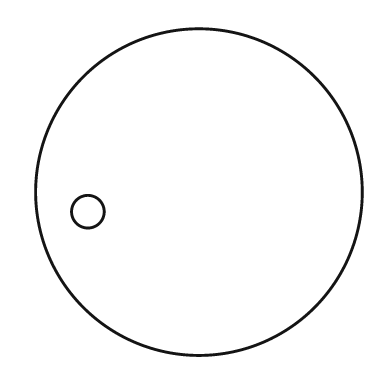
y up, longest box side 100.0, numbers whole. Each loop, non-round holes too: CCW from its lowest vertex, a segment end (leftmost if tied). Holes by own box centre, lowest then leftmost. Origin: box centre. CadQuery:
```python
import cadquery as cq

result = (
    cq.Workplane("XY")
    .moveTo(0.0, 0.0)
    .circle(50.0)
    .moveTo(-34.0, -6.0)
    .circle(5.0)
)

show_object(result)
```